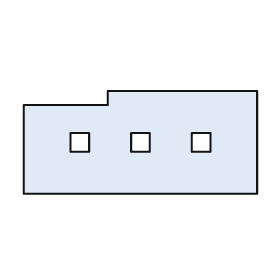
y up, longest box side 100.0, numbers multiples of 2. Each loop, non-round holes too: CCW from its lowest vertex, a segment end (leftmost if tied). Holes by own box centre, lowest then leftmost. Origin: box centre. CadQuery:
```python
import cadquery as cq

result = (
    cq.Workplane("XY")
    .moveTo(-50.0, -22.0)
    .lineTo(50.0, -22.0)
    .lineTo(50.0, 22.0)
    .lineTo(-14.0, 22.0)
    .lineTo(-14.0, 16.0)
    .lineTo(-50.0, 16.0)
    .close()
    .moveTo(-30.0, -4.0)
    .lineTo(-22.0, -4.0)
    .lineTo(-22.0, 4.0)
    .lineTo(-30.0, 4.0)
    .close()
    .moveTo(-4.0, -4.0)
    .lineTo(4.0, -4.0)
    .lineTo(4.0, 4.0)
    .lineTo(-4.0, 4.0)
    .close()
    .moveTo(22.0, -4.0)
    .lineTo(30.0, -4.0)
    .lineTo(30.0, 4.0)
    .lineTo(22.0, 4.0)
    .close()
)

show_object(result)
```